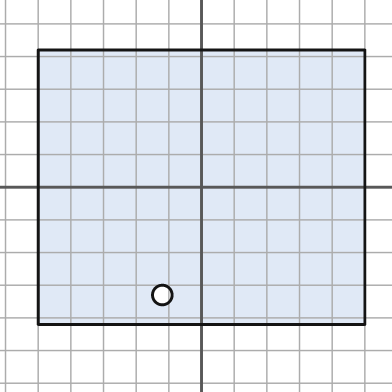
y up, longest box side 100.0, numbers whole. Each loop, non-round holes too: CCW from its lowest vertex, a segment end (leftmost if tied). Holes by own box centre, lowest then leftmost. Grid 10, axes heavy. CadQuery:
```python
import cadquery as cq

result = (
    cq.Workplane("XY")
    .moveTo(-50.0, -42.0)
    .lineTo(50.0, -42.0)
    .lineTo(50.0, 42.0)
    .lineTo(-50.0, 42.0)
    .close()
    .moveTo(-12.0, -33.0)
    .circle(3.0)
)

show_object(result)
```